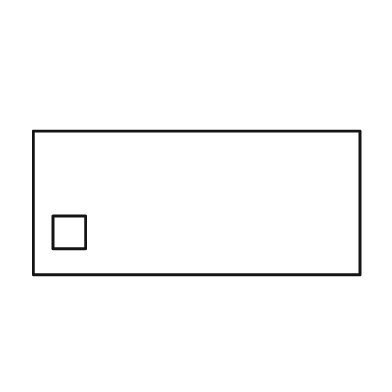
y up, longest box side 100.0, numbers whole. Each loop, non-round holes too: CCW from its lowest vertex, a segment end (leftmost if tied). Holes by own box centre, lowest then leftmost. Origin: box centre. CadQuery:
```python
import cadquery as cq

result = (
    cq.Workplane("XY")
    .moveTo(-50.0, -22.0)
    .lineTo(50.0, -22.0)
    .lineTo(50.0, 22.0)
    .lineTo(-50.0, 22.0)
    .close()
    .moveTo(-44.0, -14.0)
    .lineTo(-34.0, -14.0)
    .lineTo(-34.0, -4.0)
    .lineTo(-44.0, -4.0)
    .close()
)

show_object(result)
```